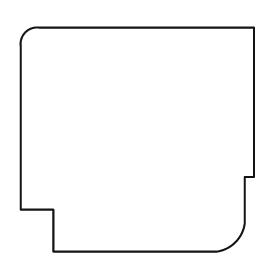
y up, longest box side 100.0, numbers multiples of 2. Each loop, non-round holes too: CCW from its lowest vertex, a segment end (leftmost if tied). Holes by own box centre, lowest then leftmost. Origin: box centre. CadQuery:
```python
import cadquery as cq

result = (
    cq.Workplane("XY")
    .moveTo(-36.0, -48.0)
    .lineTo(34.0, -48.0)
    .threePointArc((42.0, -44.0), (46.0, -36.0))
    .lineTo(46.0, -16.0)
    .lineTo(50.0, -16.0)
    .lineTo(50.0, 48.0)
    .lineTo(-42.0, 48.0)
    .threePointArc((-48.0, 46.0), (-50.0, 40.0))
    .lineTo(-50.0, -30.0)
    .lineTo(-36.0, -30.0)
    .close()
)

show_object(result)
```